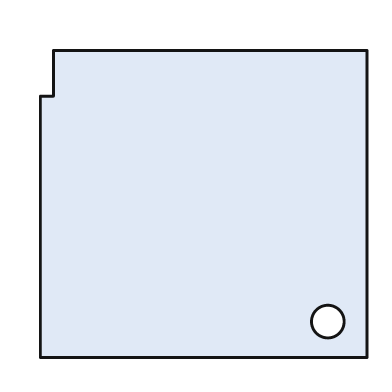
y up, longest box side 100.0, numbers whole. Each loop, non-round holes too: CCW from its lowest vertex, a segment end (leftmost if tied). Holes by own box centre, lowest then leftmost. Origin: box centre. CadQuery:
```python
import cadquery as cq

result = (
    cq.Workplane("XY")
    .moveTo(-50.0, -47.0)
    .lineTo(50.0, -47.0)
    .lineTo(50.0, 47.0)
    .lineTo(-46.0, 47.0)
    .lineTo(-46.0, 33.0)
    .lineTo(-50.0, 33.0)
    .close()
    .moveTo(38.0, -36.0)
    .circle(5.0)
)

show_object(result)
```